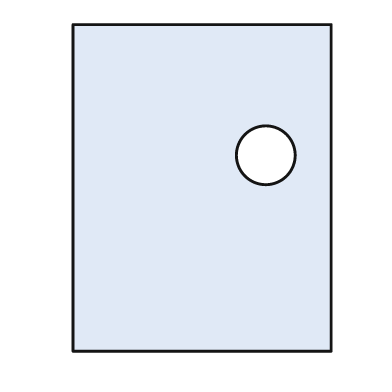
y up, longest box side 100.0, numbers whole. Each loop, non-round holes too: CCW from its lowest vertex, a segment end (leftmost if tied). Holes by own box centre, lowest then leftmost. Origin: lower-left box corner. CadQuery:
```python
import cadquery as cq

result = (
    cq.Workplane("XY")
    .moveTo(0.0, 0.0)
    .lineTo(79.0, 0.0)
    .lineTo(79.0, 100.0)
    .lineTo(0.0, 100.0)
    .close()
    .moveTo(59.0, 60.0)
    .circle(9.0)
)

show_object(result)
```